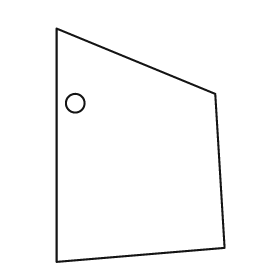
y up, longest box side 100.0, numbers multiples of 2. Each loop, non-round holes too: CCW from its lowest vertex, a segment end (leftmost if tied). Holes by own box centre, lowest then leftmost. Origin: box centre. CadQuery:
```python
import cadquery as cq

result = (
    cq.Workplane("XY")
    .moveTo(-36.0, -50.0)
    .lineTo(36.0, -44.0)
    .lineTo(32.0, 22.0)
    .lineTo(-36.0, 50.0)
    .close()
    .moveTo(-28.0, 18.0)
    .circle(4.0)
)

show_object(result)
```